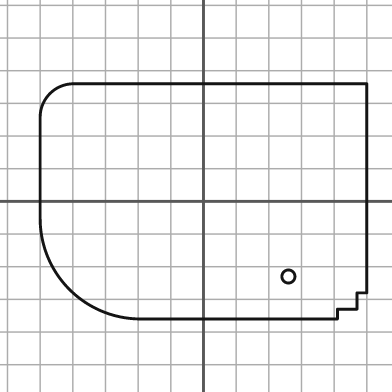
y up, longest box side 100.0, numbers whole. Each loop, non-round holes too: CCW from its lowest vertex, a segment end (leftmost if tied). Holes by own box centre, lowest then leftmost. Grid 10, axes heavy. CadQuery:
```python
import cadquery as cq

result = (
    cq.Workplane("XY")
    .moveTo(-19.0, -36.0)
    .lineTo(41.0, -36.0)
    .lineTo(41.0, -33.0)
    .lineTo(47.0, -33.0)
    .lineTo(47.0, -28.0)
    .lineTo(50.0, -28.0)
    .lineTo(50.0, 36.0)
    .lineTo(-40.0, 36.0)
    .threePointArc((-47.0, 33.0), (-50.0, 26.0))
    .lineTo(-50.0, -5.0)
    .threePointArc((-41.0, -27.0), (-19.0, -36.0))
    .close()
    .moveTo(26.0, -23.0)
    .circle(2.0)
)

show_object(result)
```